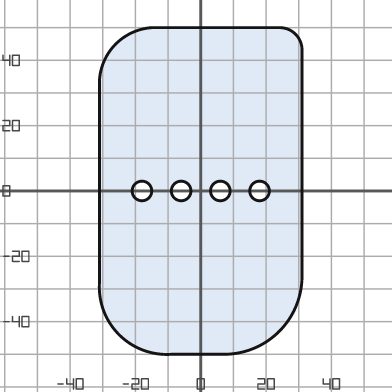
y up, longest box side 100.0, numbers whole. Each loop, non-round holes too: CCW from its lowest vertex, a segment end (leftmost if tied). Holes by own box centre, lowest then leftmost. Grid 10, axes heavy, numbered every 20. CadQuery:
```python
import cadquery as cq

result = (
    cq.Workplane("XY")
    .moveTo(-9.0, -50.0)
    .lineTo(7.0, -50.0)
    .threePointArc((24.0, -43.0), (31.0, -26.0))
    .lineTo(31.0, 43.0)
    .threePointArc((29.0, 48.0), (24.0, 50.0))
    .lineTo(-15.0, 50.0)
    .threePointArc((-26.0, 45.0), (-31.0, 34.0))
    .lineTo(-31.0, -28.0)
    .threePointArc((-25.0, -44.0), (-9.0, -50.0))
    .close()
    .moveTo(-18.0, 0.0)
    .circle(3.0)
    .moveTo(-6.0, 0.0)
    .circle(3.0)
    .moveTo(6.0, 0.0)
    .circle(3.0)
    .moveTo(18.0, 0.0)
    .circle(3.0)
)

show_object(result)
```